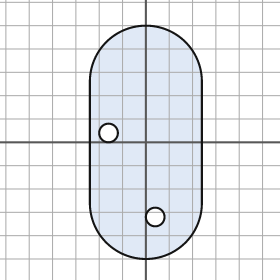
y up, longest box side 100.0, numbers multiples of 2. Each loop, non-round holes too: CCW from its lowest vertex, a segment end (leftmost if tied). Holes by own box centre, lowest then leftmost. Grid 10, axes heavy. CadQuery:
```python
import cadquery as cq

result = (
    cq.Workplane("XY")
    .moveTo(-24.0, -26.0)
    .threePointArc((0.0, -50.0), (24.0, -26.0))
    .lineTo(24.0, 26.0)
    .threePointArc((0.0, 50.0), (-24.0, 26.0))
    .close()
    .moveTo(4.0, -32.0)
    .circle(4.0)
    .moveTo(-16.0, 4.0)
    .circle(4.0)
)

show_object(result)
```